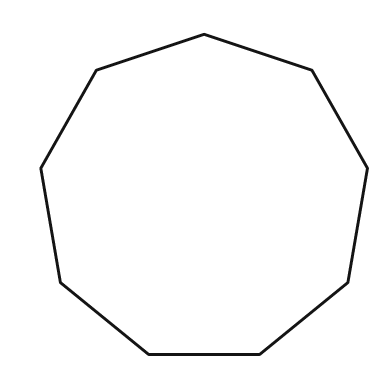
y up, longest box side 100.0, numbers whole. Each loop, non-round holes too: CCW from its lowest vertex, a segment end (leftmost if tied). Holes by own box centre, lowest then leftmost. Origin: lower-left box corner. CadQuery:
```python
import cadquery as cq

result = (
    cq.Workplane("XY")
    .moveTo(33.0, 0.0)
    .lineTo(67.0, 0.0)
    .lineTo(94.0, 22.0)
    .lineTo(100.0, 57.0)
    .lineTo(83.0, 87.0)
    .lineTo(50.0, 98.0)
    .lineTo(17.0, 87.0)
    .lineTo(0.0, 57.0)
    .lineTo(6.0, 22.0)
    .close()
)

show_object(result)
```